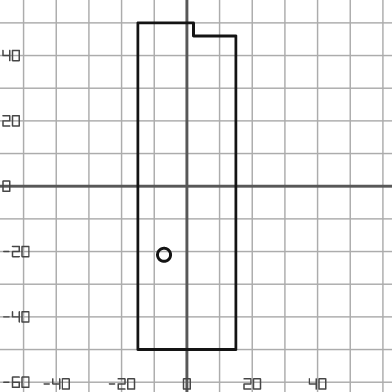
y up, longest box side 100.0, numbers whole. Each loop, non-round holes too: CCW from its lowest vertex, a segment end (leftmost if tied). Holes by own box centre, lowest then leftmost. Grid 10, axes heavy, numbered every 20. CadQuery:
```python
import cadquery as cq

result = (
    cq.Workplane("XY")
    .moveTo(-15.0, -50.0)
    .lineTo(15.0, -50.0)
    .lineTo(15.0, 46.0)
    .lineTo(2.0, 46.0)
    .lineTo(2.0, 50.0)
    .lineTo(-15.0, 50.0)
    .close()
    .moveTo(-7.0, -21.0)
    .circle(2.0)
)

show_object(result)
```